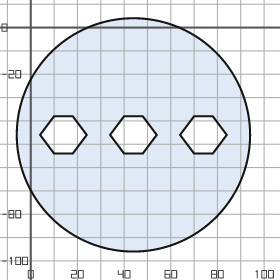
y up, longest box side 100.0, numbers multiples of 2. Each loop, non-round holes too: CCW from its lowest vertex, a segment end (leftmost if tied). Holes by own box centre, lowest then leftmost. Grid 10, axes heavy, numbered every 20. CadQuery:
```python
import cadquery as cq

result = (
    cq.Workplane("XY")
    .moveTo(44.0, -46.0)
    .circle(50.0)
    .moveTo(10.0, -54.0)
    .lineTo(18.0, -54.0)
    .lineTo(24.0, -46.0)
    .lineTo(18.0, -38.0)
    .lineTo(10.0, -38.0)
    .lineTo(4.0, -46.0)
    .close()
    .moveTo(40.0, -54.0)
    .lineTo(48.0, -54.0)
    .lineTo(54.0, -46.0)
    .lineTo(48.0, -38.0)
    .lineTo(40.0, -38.0)
    .lineTo(34.0, -46.0)
    .close()
    .moveTo(70.0, -54.0)
    .lineTo(78.0, -54.0)
    .lineTo(84.0, -46.0)
    .lineTo(78.0, -38.0)
    .lineTo(70.0, -38.0)
    .lineTo(64.0, -46.0)
    .close()
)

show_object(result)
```